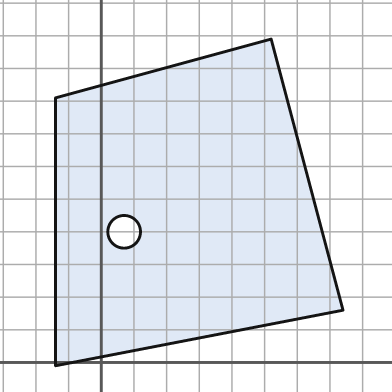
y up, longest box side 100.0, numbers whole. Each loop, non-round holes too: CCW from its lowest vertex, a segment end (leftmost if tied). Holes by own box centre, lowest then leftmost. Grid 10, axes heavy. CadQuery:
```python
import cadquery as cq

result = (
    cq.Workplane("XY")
    .moveTo(-14.0, -1.0)
    .lineTo(74.0, 16.0)
    .lineTo(52.0, 99.0)
    .lineTo(-14.0, 81.0)
    .close()
    .moveTo(7.0, 40.0)
    .circle(5.0)
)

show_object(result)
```